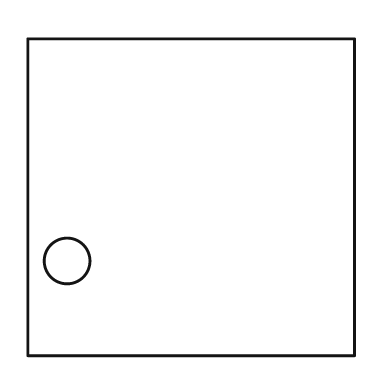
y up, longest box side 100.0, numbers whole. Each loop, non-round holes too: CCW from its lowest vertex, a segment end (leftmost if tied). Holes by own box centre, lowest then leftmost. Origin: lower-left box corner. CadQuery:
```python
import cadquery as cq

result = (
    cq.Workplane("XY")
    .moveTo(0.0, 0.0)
    .lineTo(100.0, 0.0)
    .lineTo(100.0, 97.0)
    .lineTo(0.0, 97.0)
    .close()
    .moveTo(12.0, 29.0)
    .circle(7.0)
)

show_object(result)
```